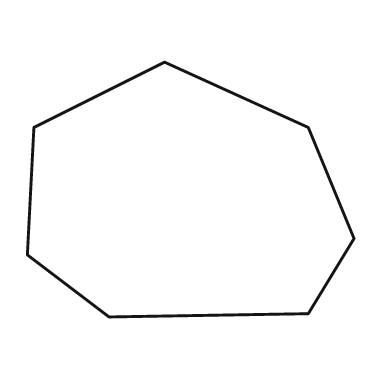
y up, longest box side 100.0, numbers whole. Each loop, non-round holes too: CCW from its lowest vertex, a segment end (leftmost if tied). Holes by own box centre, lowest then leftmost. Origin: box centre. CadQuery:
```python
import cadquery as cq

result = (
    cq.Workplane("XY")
    .moveTo(-25.0, -39.0)
    .lineTo(36.0, -38.0)
    .lineTo(50.0, -15.0)
    .lineTo(36.0, 19.0)
    .lineTo(-8.0, 39.0)
    .lineTo(-48.0, 19.0)
    .lineTo(-50.0, -20.0)
    .close()
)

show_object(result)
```